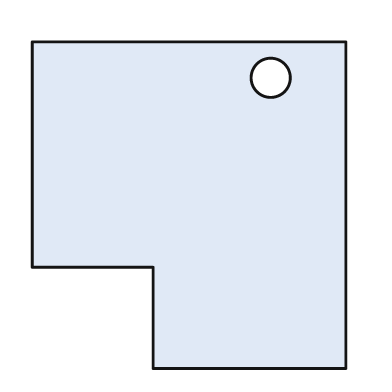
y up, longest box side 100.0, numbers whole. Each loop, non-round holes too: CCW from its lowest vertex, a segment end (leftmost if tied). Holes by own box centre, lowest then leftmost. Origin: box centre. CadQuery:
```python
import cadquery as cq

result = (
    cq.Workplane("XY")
    .moveTo(-11.0, -50.0)
    .lineTo(48.0, -50.0)
    .lineTo(48.0, 50.0)
    .lineTo(-48.0, 50.0)
    .lineTo(-48.0, -19.0)
    .lineTo(-11.0, -19.0)
    .close()
    .moveTo(25.0, 39.0)
    .circle(6.0)
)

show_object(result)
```